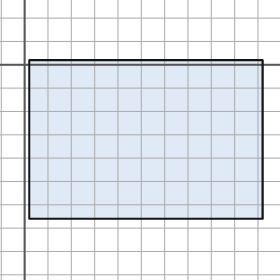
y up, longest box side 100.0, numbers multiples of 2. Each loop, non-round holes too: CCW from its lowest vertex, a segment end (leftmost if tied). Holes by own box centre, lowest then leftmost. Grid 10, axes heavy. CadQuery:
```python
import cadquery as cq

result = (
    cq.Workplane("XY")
    .moveTo(2.0, -66.0)
    .lineTo(102.0, -66.0)
    .lineTo(102.0, 2.0)
    .lineTo(2.0, 2.0)
    .close()
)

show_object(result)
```